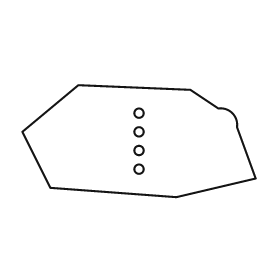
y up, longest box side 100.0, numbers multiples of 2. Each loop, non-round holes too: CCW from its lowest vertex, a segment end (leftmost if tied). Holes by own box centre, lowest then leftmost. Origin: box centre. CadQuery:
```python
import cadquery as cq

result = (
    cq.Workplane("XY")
    .moveTo(16.0, -24.0)
    .lineTo(50.0, -16.0)
    .lineTo(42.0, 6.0)
    .threePointArc((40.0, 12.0), (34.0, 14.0))
    .lineTo(22.0, 22.0)
    .lineTo(-26.0, 24.0)
    .lineTo(-50.0, 4.0)
    .lineTo(-38.0, -20.0)
    .close()
    .moveTo(0.0, -12.0)
    .circle(2.0)
    .moveTo(0.0, -4.0)
    .circle(2.0)
    .moveTo(0.0, 4.0)
    .circle(2.0)
    .moveTo(0.0, 12.0)
    .circle(2.0)
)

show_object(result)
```